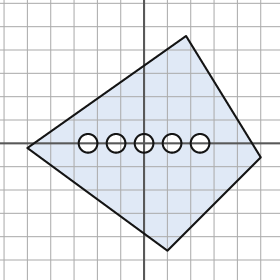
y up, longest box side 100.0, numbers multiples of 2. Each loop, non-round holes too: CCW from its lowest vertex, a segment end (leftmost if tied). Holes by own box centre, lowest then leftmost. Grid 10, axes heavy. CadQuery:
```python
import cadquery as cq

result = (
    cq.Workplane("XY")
    .moveTo(10.0, -46.0)
    .lineTo(50.0, -6.0)
    .lineTo(18.0, 46.0)
    .lineTo(-50.0, -2.0)
    .close()
    .moveTo(-24.0, 0.0)
    .circle(4.0)
    .moveTo(-12.0, 0.0)
    .circle(4.0)
    .moveTo(0.0, 0.0)
    .circle(4.0)
    .moveTo(12.0, 0.0)
    .circle(4.0)
    .moveTo(24.0, 0.0)
    .circle(4.0)
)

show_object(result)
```